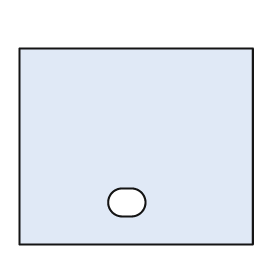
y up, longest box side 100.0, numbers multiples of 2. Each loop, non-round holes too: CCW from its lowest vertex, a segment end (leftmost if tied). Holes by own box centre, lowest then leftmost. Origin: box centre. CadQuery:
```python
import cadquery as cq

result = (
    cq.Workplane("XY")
    .moveTo(-50.0, -42.0)
    .lineTo(50.0, -42.0)
    .lineTo(50.0, 42.0)
    .lineTo(-50.0, 42.0)
    .close()
    .moveTo(-6.0, -30.0)
    .lineTo(-2.0, -30.0)
    .threePointArc((4.0, -24.0), (-2.0, -18.0))
    .lineTo(-6.0, -18.0)
    .threePointArc((-12.0, -24.0), (-6.0, -30.0))
    .close()
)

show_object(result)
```